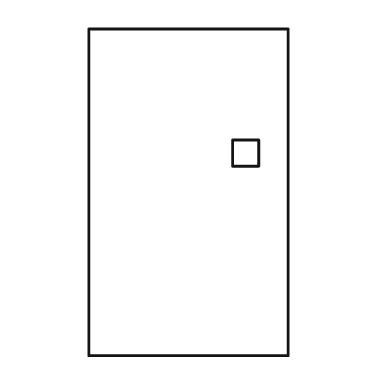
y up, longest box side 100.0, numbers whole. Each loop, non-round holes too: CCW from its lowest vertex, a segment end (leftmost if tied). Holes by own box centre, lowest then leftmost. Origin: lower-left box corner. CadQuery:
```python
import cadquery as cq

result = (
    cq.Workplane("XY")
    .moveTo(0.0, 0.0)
    .lineTo(61.0, 0.0)
    .lineTo(61.0, 100.0)
    .lineTo(0.0, 100.0)
    .close()
    .moveTo(44.0, 58.0)
    .lineTo(52.0, 58.0)
    .lineTo(52.0, 66.0)
    .lineTo(44.0, 66.0)
    .close()
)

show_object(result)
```